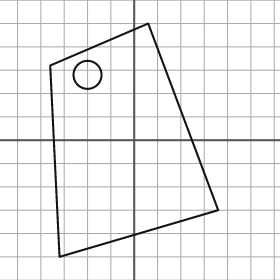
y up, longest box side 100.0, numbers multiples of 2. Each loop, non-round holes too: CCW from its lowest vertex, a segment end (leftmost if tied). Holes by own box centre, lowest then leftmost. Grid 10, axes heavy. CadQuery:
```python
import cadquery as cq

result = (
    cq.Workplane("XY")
    .moveTo(-32.0, -50.0)
    .lineTo(36.0, -30.0)
    .lineTo(6.0, 50.0)
    .lineTo(-36.0, 32.0)
    .close()
    .moveTo(-20.0, 28.0)
    .circle(6.0)
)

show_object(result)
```